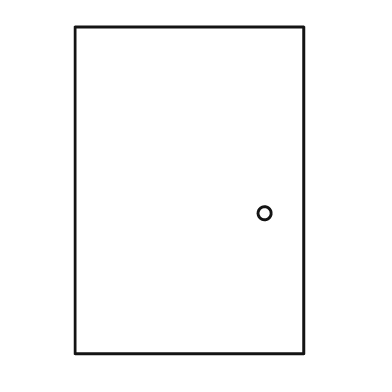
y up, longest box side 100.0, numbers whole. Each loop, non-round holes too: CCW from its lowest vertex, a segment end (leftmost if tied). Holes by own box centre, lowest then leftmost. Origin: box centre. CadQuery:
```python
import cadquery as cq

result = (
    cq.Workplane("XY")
    .moveTo(-35.0, -50.0)
    .lineTo(35.0, -50.0)
    .lineTo(35.0, 50.0)
    .lineTo(-35.0, 50.0)
    .close()
    .moveTo(23.0, -7.0)
    .circle(2.0)
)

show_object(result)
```